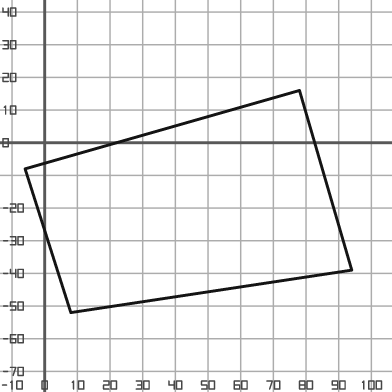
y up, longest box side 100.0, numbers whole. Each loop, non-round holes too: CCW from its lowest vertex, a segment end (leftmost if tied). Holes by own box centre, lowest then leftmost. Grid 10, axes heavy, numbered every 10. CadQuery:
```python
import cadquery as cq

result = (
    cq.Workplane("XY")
    .moveTo(8.0, -52.0)
    .lineTo(94.0, -39.0)
    .lineTo(78.0, 16.0)
    .lineTo(-6.0, -8.0)
    .close()
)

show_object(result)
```